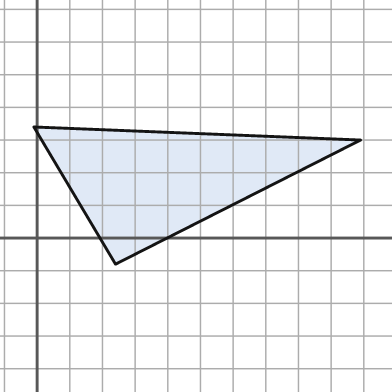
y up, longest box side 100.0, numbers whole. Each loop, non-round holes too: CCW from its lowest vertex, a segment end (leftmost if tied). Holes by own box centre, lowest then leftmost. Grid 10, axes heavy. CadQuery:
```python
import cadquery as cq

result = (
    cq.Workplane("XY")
    .moveTo(24.0, -8.0)
    .lineTo(99.0, 30.0)
    .lineTo(-1.0, 34.0)
    .close()
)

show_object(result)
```